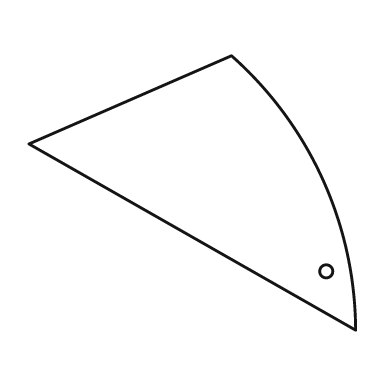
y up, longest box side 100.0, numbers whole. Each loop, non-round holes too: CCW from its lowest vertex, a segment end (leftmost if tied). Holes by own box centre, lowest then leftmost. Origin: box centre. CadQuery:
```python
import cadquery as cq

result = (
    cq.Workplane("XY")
    .moveTo(50.0, -42.0)
    .threePointArc((40.0, 4.0), (12.0, 42.0))
    .lineTo(-50.0, 15.0)
    .close()
    .moveTo(41.0, -24.0)
    .circle(2.0)
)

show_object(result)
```